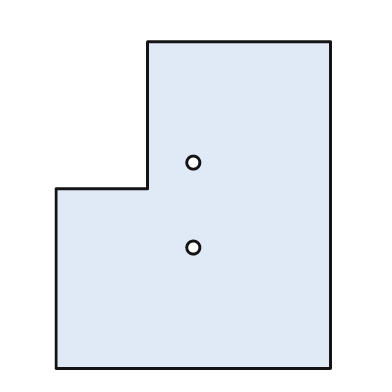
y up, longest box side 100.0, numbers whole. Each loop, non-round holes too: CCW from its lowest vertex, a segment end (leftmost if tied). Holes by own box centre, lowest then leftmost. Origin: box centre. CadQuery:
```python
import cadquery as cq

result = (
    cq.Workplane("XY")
    .moveTo(-42.0, -50.0)
    .lineTo(42.0, -50.0)
    .lineTo(42.0, 50.0)
    .lineTo(-14.0, 50.0)
    .lineTo(-14.0, 5.0)
    .lineTo(-42.0, 5.0)
    .close()
    .moveTo(0.0, -13.0)
    .circle(2.0)
    .moveTo(0.0, 13.0)
    .circle(2.0)
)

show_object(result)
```